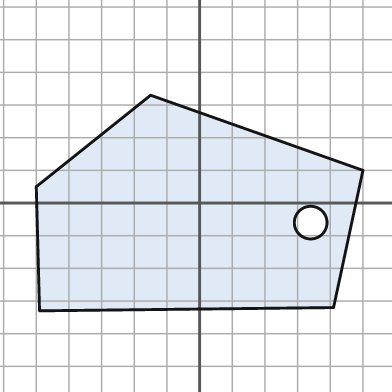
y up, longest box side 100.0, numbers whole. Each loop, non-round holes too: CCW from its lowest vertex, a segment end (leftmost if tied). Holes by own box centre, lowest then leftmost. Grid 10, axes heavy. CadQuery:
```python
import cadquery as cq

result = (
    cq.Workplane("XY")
    .moveTo(-49.0, -33.0)
    .lineTo(41.0, -32.0)
    .lineTo(50.0, 10.0)
    .lineTo(-15.0, 33.0)
    .lineTo(-50.0, 5.0)
    .close()
    .moveTo(34.0, -6.0)
    .circle(5.0)
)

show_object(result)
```